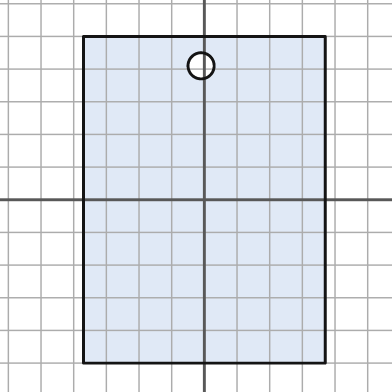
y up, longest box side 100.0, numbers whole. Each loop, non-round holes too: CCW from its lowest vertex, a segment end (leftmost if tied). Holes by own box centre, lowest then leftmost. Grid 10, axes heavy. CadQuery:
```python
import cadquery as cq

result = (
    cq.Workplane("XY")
    .moveTo(-37.0, -50.0)
    .lineTo(37.0, -50.0)
    .lineTo(37.0, 50.0)
    .lineTo(-37.0, 50.0)
    .close()
    .moveTo(-1.0, 41.0)
    .circle(4.0)
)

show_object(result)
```